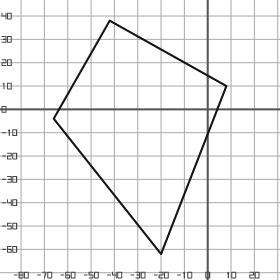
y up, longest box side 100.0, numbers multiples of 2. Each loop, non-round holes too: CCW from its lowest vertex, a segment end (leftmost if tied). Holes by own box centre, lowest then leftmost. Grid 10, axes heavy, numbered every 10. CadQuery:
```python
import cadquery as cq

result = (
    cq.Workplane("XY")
    .moveTo(-20.0, -62.0)
    .lineTo(8.0, 10.0)
    .lineTo(-42.0, 38.0)
    .lineTo(-66.0, -4.0)
    .close()
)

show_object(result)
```